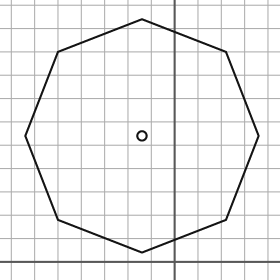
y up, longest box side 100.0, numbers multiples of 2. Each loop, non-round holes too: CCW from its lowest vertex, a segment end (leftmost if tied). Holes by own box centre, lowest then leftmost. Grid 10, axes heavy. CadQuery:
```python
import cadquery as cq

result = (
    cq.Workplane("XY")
    .moveTo(-14.0, 4.0)
    .lineTo(22.0, 18.0)
    .lineTo(36.0, 54.0)
    .lineTo(22.0, 90.0)
    .lineTo(-14.0, 104.0)
    .lineTo(-50.0, 90.0)
    .lineTo(-64.0, 54.0)
    .lineTo(-50.0, 18.0)
    .close()
    .moveTo(-14.0, 54.0)
    .circle(2.0)
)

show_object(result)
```